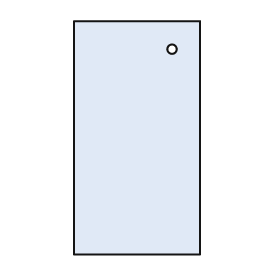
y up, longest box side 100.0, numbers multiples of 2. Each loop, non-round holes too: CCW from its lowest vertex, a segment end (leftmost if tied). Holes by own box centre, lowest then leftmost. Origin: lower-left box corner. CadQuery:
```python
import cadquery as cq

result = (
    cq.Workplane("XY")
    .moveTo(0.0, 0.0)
    .lineTo(54.0, 0.0)
    .lineTo(54.0, 100.0)
    .lineTo(0.0, 100.0)
    .close()
    .moveTo(42.0, 88.0)
    .circle(2.0)
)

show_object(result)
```